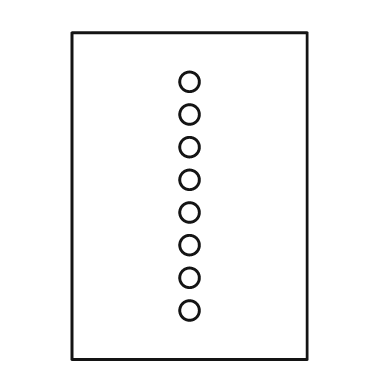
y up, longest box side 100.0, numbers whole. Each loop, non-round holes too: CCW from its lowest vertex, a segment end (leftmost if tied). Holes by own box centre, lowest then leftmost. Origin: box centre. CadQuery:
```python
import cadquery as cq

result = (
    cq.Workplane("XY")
    .moveTo(-36.0, -50.0)
    .lineTo(36.0, -50.0)
    .lineTo(36.0, 50.0)
    .lineTo(-36.0, 50.0)
    .close()
    .moveTo(0.0, -35.0)
    .circle(3.0)
    .moveTo(0.0, -25.0)
    .circle(3.0)
    .moveTo(0.0, -15.0)
    .circle(3.0)
    .moveTo(0.0, -5.0)
    .circle(3.0)
    .moveTo(0.0, 5.0)
    .circle(3.0)
    .moveTo(0.0, 15.0)
    .circle(3.0)
    .moveTo(0.0, 25.0)
    .circle(3.0)
    .moveTo(0.0, 35.0)
    .circle(3.0)
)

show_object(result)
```